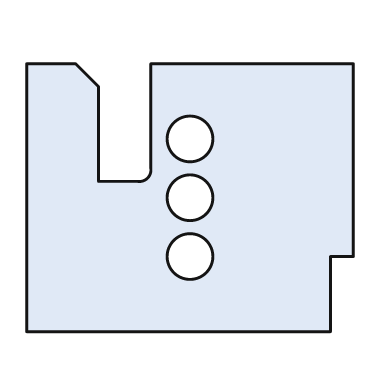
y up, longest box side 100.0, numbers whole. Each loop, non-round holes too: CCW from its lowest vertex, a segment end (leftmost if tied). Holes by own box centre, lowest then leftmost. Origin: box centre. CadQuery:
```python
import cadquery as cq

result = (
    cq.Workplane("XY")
    .moveTo(-50.0, -41.0)
    .lineTo(43.0, -41.0)
    .lineTo(43.0, -18.0)
    .lineTo(50.0, -18.0)
    .lineTo(50.0, 41.0)
    .lineTo(-12.0, 41.0)
    .lineTo(-12.0, 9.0)
    .threePointArc((-13.0, 6.0), (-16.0, 5.0))
    .lineTo(-28.0, 5.0)
    .lineTo(-28.0, 34.0)
    .lineTo(-35.0, 41.0)
    .lineTo(-50.0, 41.0)
    .close()
    .moveTo(0.0, -18.0)
    .circle(7.0)
    .moveTo(0.0, 0.0)
    .circle(7.0)
    .moveTo(0.0, 18.0)
    .circle(7.0)
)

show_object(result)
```